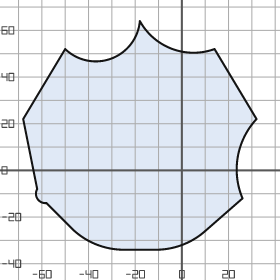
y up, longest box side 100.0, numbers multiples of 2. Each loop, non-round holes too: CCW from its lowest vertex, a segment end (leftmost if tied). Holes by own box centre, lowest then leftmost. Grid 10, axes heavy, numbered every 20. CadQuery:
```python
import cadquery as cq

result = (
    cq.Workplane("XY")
    .moveTo(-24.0, -34.0)
    .lineTo(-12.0, -34.0)
    .threePointArc((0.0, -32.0), (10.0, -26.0))
    .lineTo(26.0, -12.0)
    .threePointArc((24.0, 6.0), (32.0, 22.0))
    .lineTo(14.0, 52.0)
    .threePointArc((-4.0, 52.0), (-18.0, 64.0))
    .threePointArc((-30.0, 48.0), (-50.0, 52.0))
    .lineTo(-68.0, 22.0)
    .lineTo(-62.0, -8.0)
    .threePointArc((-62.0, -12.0), (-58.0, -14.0))
    .lineTo(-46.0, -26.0)
    .threePointArc((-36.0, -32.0), (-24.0, -34.0))
    .close()
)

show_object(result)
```